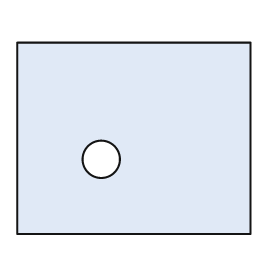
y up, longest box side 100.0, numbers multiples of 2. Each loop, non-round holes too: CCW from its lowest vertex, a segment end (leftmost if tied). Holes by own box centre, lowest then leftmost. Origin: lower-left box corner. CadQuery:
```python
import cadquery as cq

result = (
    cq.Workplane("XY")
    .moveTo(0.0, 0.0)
    .lineTo(100.0, 0.0)
    .lineTo(100.0, 82.0)
    .lineTo(0.0, 82.0)
    .close()
    .moveTo(36.0, 32.0)
    .circle(8.0)
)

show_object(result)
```